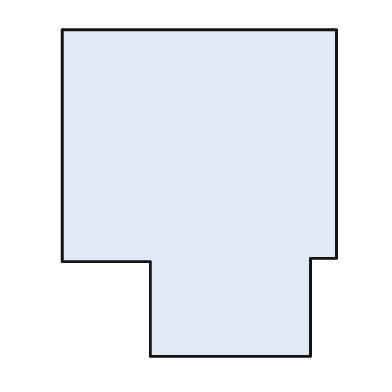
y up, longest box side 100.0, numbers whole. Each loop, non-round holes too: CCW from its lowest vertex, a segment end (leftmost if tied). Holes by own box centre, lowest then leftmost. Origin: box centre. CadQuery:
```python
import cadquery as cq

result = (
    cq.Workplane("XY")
    .moveTo(-15.0, -50.0)
    .lineTo(34.0, -50.0)
    .lineTo(34.0, -20.0)
    .lineTo(42.0, -20.0)
    .lineTo(42.0, 50.0)
    .lineTo(-42.0, 50.0)
    .lineTo(-42.0, -21.0)
    .lineTo(-15.0, -21.0)
    .close()
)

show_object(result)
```